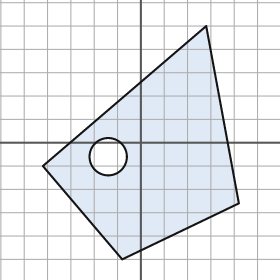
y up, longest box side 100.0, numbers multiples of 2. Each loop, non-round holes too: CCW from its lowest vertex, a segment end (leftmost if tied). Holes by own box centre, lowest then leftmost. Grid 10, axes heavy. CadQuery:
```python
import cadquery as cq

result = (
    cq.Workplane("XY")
    .moveTo(-8.0, -50.0)
    .lineTo(42.0, -26.0)
    .lineTo(28.0, 50.0)
    .lineTo(-42.0, -10.0)
    .close()
    .moveTo(-14.0, -6.0)
    .circle(8.0)
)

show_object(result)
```